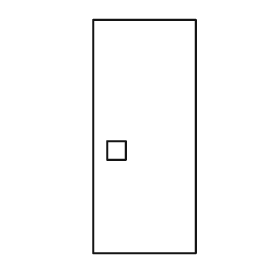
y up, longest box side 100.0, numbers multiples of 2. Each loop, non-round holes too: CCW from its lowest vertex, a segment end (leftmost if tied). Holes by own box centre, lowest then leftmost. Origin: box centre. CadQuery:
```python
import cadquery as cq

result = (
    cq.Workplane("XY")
    .moveTo(-22.0, -50.0)
    .lineTo(22.0, -50.0)
    .lineTo(22.0, 50.0)
    .lineTo(-22.0, 50.0)
    .close()
    .moveTo(-16.0, -10.0)
    .lineTo(-8.0, -10.0)
    .lineTo(-8.0, -2.0)
    .lineTo(-16.0, -2.0)
    .close()
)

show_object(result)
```